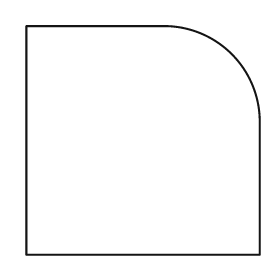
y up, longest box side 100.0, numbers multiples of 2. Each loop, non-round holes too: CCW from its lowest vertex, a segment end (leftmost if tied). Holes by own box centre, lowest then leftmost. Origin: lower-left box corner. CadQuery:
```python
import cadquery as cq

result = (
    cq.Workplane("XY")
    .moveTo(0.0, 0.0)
    .lineTo(100.0, 0.0)
    .lineTo(100.0, 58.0)
    .threePointArc((88.0, 86.0), (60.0, 98.0))
    .lineTo(0.0, 98.0)
    .close()
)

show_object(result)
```